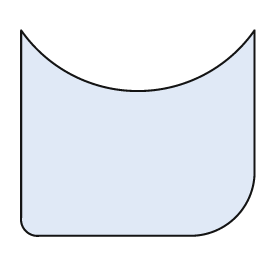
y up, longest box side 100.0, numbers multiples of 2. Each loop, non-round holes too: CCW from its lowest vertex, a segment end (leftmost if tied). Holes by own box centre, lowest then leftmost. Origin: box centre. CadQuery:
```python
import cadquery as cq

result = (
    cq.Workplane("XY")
    .moveTo(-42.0, -44.0)
    .lineTo(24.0, -44.0)
    .threePointArc((42.0, -36.0), (50.0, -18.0))
    .lineTo(50.0, 44.0)
    .threePointArc((0.0, 18.0), (-50.0, 44.0))
    .lineTo(-50.0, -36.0)
    .threePointArc((-48.0, -42.0), (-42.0, -44.0))
    .close()
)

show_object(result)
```